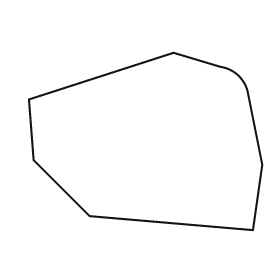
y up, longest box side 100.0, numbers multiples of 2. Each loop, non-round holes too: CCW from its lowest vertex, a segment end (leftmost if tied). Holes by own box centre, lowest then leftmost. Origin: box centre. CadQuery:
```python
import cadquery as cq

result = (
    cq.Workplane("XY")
    .moveTo(46.0, -38.0)
    .lineTo(50.0, -10.0)
    .lineTo(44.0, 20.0)
    .threePointArc((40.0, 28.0), (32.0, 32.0))
    .lineTo(12.0, 38.0)
    .lineTo(-50.0, 18.0)
    .lineTo(-48.0, -8.0)
    .lineTo(-24.0, -32.0)
    .close()
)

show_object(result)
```